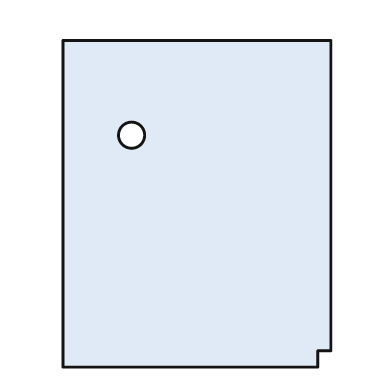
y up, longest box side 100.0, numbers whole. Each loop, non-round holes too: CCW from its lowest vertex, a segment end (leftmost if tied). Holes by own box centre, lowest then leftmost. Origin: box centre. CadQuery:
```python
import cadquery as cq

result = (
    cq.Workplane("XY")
    .moveTo(-41.0, -50.0)
    .lineTo(37.0, -50.0)
    .lineTo(37.0, -45.0)
    .lineTo(41.0, -45.0)
    .lineTo(41.0, 50.0)
    .lineTo(-41.0, 50.0)
    .close()
    .moveTo(-20.0, 21.0)
    .circle(4.0)
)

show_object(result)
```